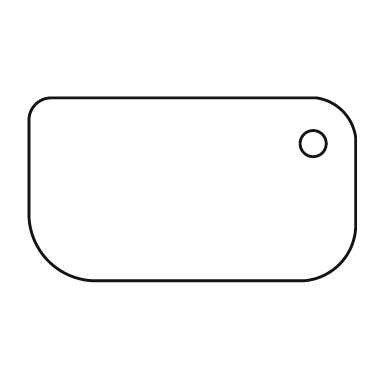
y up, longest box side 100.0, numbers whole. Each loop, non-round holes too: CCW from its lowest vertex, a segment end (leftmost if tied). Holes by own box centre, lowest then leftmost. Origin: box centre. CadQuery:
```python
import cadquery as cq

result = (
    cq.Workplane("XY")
    .moveTo(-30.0, -28.0)
    .lineTo(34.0, -28.0)
    .threePointArc((45.0, -23.0), (50.0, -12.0))
    .lineTo(50.0, 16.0)
    .threePointArc((46.0, 24.0), (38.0, 28.0))
    .lineTo(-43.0, 28.0)
    .threePointArc((-48.0, 26.0), (-50.0, 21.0))
    .lineTo(-50.0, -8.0)
    .threePointArc((-44.0, -22.0), (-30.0, -28.0))
    .close()
    .moveTo(37.0, 14.0)
    .circle(4.0)
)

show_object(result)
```